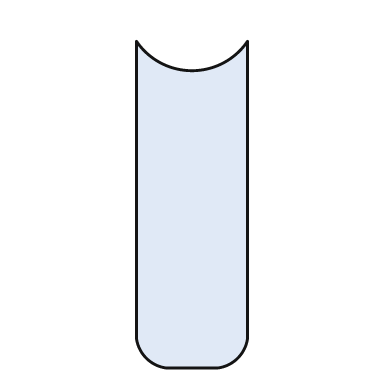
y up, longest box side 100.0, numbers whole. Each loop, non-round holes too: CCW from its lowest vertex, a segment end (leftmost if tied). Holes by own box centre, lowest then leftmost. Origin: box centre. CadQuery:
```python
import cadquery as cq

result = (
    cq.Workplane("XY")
    .moveTo(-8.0, -50.0)
    .lineTo(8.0, -50.0)
    .threePointArc((14.0, -47.0), (17.0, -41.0))
    .lineTo(17.0, 50.0)
    .threePointArc((0.0, 41.0), (-17.0, 50.0))
    .lineTo(-17.0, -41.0)
    .threePointArc((-14.0, -47.0), (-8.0, -50.0))
    .close()
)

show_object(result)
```